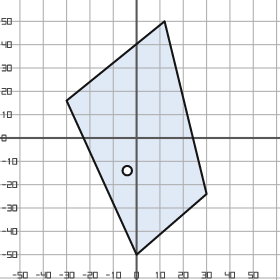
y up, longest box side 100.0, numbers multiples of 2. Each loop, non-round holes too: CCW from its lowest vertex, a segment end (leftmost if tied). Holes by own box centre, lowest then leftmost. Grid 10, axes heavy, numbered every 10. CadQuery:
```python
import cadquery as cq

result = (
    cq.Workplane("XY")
    .moveTo(0.0, -50.0)
    .lineTo(30.0, -24.0)
    .lineTo(12.0, 50.0)
    .lineTo(-30.0, 16.0)
    .close()
    .moveTo(-4.0, -14.0)
    .circle(2.0)
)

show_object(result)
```